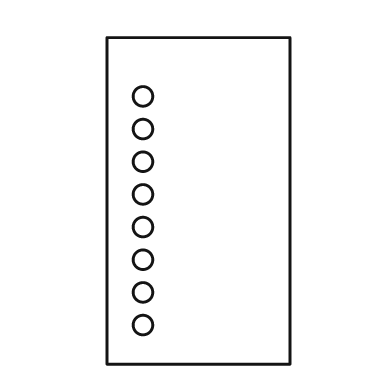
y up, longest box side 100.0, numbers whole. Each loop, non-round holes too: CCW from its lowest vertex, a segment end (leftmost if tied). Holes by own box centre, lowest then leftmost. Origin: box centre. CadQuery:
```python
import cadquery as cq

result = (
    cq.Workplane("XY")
    .moveTo(-28.0, -50.0)
    .lineTo(28.0, -50.0)
    .lineTo(28.0, 50.0)
    .lineTo(-28.0, 50.0)
    .close()
    .moveTo(-17.0, -38.0)
    .circle(3.0)
    .moveTo(-17.0, -28.0)
    .circle(3.0)
    .moveTo(-17.0, -18.0)
    .circle(3.0)
    .moveTo(-17.0, -8.0)
    .circle(3.0)
    .moveTo(-17.0, 2.0)
    .circle(3.0)
    .moveTo(-17.0, 12.0)
    .circle(3.0)
    .moveTo(-17.0, 22.0)
    .circle(3.0)
    .moveTo(-17.0, 32.0)
    .circle(3.0)
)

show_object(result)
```